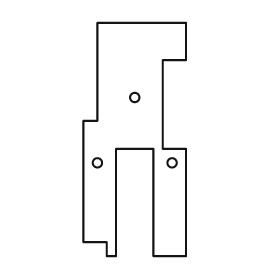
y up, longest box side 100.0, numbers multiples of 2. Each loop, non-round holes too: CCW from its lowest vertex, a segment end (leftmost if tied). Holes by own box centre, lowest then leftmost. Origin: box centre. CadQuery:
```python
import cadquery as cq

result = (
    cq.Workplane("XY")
    .moveTo(-12.0, -50.0)
    .lineTo(-8.0, -50.0)
    .lineTo(-8.0, -4.0)
    .lineTo(8.0, -4.0)
    .lineTo(8.0, -50.0)
    .lineTo(22.0, -50.0)
    .lineTo(22.0, -4.0)
    .lineTo(12.0, -4.0)
    .lineTo(12.0, 34.0)
    .lineTo(22.0, 34.0)
    .lineTo(22.0, 50.0)
    .lineTo(-16.0, 50.0)
    .lineTo(-16.0, 8.0)
    .lineTo(-22.0, 8.0)
    .lineTo(-22.0, -44.0)
    .lineTo(-12.0, -44.0)
    .close()
    .moveTo(-16.0, -10.0)
    .circle(2.0)
    .moveTo(16.0, -10.0)
    .circle(2.0)
    .moveTo(0.0, 18.0)
    .circle(2.0)
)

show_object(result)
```